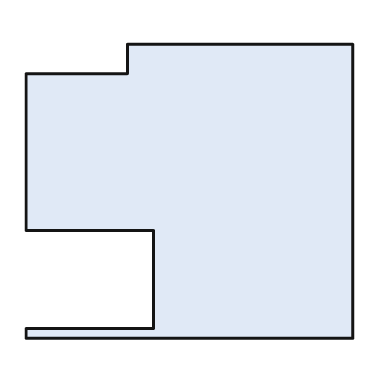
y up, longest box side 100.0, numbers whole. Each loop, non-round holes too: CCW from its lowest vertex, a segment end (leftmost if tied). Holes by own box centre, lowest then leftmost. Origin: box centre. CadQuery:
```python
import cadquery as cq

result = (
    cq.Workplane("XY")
    .moveTo(-50.0, -45.0)
    .lineTo(50.0, -45.0)
    .lineTo(50.0, 45.0)
    .lineTo(-19.0, 45.0)
    .lineTo(-19.0, 36.0)
    .lineTo(-50.0, 36.0)
    .lineTo(-50.0, -12.0)
    .lineTo(-11.0, -12.0)
    .lineTo(-11.0, -42.0)
    .lineTo(-50.0, -42.0)
    .close()
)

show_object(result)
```